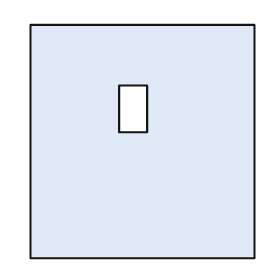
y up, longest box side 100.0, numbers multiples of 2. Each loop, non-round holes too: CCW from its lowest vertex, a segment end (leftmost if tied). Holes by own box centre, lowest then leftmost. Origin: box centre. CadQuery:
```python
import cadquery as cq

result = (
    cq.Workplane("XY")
    .moveTo(-48.0, -50.0)
    .lineTo(48.0, -50.0)
    .lineTo(48.0, 50.0)
    .lineTo(-48.0, 50.0)
    .close()
    .moveTo(-10.0, 4.0)
    .lineTo(2.0, 4.0)
    .lineTo(2.0, 24.0)
    .lineTo(-10.0, 24.0)
    .close()
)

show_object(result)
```